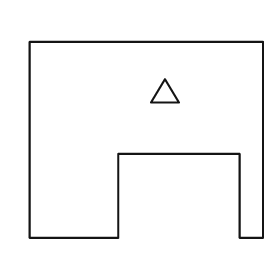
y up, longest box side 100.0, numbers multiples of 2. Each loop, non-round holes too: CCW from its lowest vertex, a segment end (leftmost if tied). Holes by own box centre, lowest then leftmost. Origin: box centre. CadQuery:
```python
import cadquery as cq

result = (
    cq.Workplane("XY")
    .moveTo(-50.0, -42.0)
    .lineTo(-12.0, -42.0)
    .lineTo(-12.0, -6.0)
    .lineTo(40.0, -6.0)
    .lineTo(40.0, -42.0)
    .lineTo(50.0, -42.0)
    .lineTo(50.0, 42.0)
    .lineTo(-50.0, 42.0)
    .close()
    .moveTo(2.0, 16.0)
    .lineTo(14.0, 16.0)
    .lineTo(8.0, 26.0)
    .close()
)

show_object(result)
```